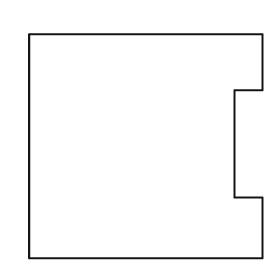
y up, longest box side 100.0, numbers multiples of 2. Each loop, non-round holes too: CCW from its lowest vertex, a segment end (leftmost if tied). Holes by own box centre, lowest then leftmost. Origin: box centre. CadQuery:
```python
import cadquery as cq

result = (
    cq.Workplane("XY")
    .moveTo(-50.0, -48.0)
    .lineTo(50.0, -48.0)
    .lineTo(50.0, -22.0)
    .lineTo(38.0, -22.0)
    .lineTo(38.0, 24.0)
    .lineTo(50.0, 24.0)
    .lineTo(50.0, 48.0)
    .lineTo(-50.0, 48.0)
    .close()
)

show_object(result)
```